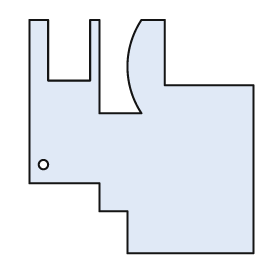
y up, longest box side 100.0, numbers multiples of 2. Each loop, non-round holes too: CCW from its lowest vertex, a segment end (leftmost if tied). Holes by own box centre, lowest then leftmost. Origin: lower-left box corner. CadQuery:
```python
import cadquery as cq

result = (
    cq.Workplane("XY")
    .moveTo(42.0, 0.0)
    .lineTo(96.0, 0.0)
    .lineTo(96.0, 72.0)
    .lineTo(58.0, 72.0)
    .lineTo(58.0, 100.0)
    .lineTo(48.0, 100.0)
    .threePointArc((42.0, 80.0), (48.0, 60.0))
    .lineTo(30.0, 60.0)
    .lineTo(30.0, 100.0)
    .lineTo(26.0, 100.0)
    .lineTo(26.0, 74.0)
    .lineTo(8.0, 74.0)
    .lineTo(8.0, 100.0)
    .lineTo(0.0, 100.0)
    .lineTo(0.0, 30.0)
    .lineTo(30.0, 30.0)
    .lineTo(30.0, 18.0)
    .lineTo(42.0, 18.0)
    .close()
    .moveTo(6.0, 38.0)
    .circle(2.0)
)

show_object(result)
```